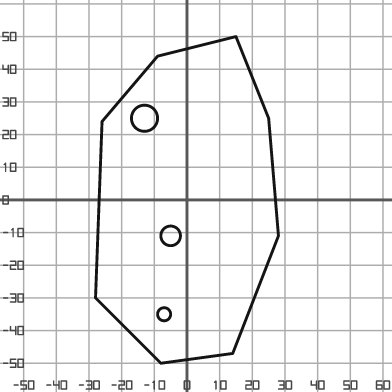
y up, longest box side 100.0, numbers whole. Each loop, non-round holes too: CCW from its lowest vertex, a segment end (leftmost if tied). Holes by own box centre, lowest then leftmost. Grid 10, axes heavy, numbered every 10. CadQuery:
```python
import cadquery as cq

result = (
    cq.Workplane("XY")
    .moveTo(-8.0, -50.0)
    .lineTo(14.0, -47.0)
    .lineTo(28.0, -11.0)
    .lineTo(25.0, 25.0)
    .lineTo(15.0, 50.0)
    .lineTo(-9.0, 44.0)
    .lineTo(-26.0, 24.0)
    .lineTo(-28.0, -30.0)
    .close()
    .moveTo(-7.0, -35.0)
    .circle(2.0)
    .moveTo(-5.0, -11.0)
    .circle(3.0)
    .moveTo(-13.0, 25.0)
    .circle(4.0)
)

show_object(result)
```